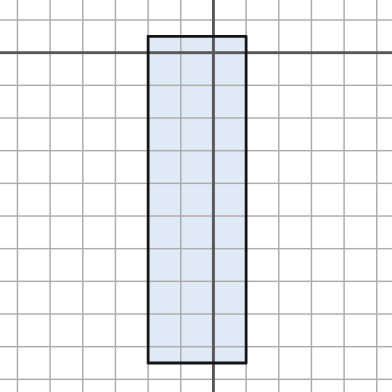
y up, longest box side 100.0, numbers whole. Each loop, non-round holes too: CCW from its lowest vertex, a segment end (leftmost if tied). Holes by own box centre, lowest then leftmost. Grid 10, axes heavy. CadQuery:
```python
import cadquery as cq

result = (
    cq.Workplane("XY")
    .moveTo(-20.0, -95.0)
    .lineTo(10.0, -95.0)
    .lineTo(10.0, 5.0)
    .lineTo(-20.0, 5.0)
    .close()
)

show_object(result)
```